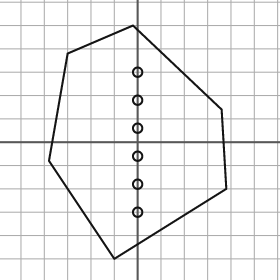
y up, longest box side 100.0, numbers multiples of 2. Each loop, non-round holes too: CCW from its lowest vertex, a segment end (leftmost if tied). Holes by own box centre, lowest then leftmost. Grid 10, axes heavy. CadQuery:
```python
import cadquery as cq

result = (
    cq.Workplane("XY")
    .moveTo(-10.0, -50.0)
    .lineTo(38.0, -20.0)
    .lineTo(36.0, 14.0)
    .lineTo(-2.0, 50.0)
    .lineTo(-30.0, 38.0)
    .lineTo(-38.0, -8.0)
    .close()
    .moveTo(0.0, -30.0)
    .circle(2.0)
    .moveTo(0.0, -18.0)
    .circle(2.0)
    .moveTo(0.0, -6.0)
    .circle(2.0)
    .moveTo(0.0, 6.0)
    .circle(2.0)
    .moveTo(0.0, 18.0)
    .circle(2.0)
    .moveTo(0.0, 30.0)
    .circle(2.0)
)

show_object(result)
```